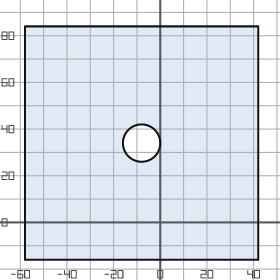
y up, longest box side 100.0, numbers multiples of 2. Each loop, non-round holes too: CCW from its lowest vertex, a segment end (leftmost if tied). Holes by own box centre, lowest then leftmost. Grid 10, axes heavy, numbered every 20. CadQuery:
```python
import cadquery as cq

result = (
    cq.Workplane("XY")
    .moveTo(-58.0, -16.0)
    .lineTo(42.0, -16.0)
    .lineTo(42.0, 84.0)
    .lineTo(-58.0, 84.0)
    .close()
    .moveTo(-8.0, 34.0)
    .circle(8.0)
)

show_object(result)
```